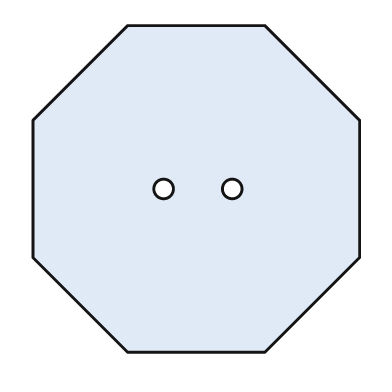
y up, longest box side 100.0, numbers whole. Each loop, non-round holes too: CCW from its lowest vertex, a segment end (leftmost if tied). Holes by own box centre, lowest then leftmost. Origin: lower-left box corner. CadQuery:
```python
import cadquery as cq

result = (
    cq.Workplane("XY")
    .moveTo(29.0, 0.0)
    .lineTo(71.0, 0.0)
    .lineTo(100.0, 29.0)
    .lineTo(100.0, 71.0)
    .lineTo(71.0, 100.0)
    .lineTo(29.0, 100.0)
    .lineTo(0.0, 71.0)
    .lineTo(0.0, 29.0)
    .close()
    .moveTo(40.0, 50.0)
    .circle(3.0)
    .moveTo(61.0, 50.0)
    .circle(3.0)
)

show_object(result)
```